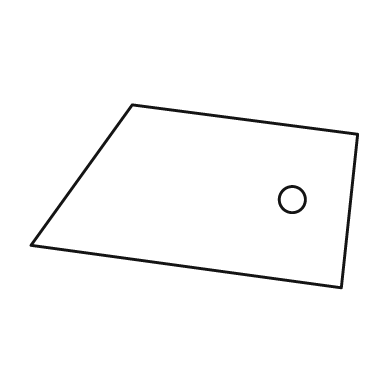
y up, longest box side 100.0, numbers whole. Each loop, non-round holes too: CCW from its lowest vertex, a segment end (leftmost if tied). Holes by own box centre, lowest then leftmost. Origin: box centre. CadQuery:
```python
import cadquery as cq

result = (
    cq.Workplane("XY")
    .moveTo(45.0, -28.0)
    .lineTo(50.0, 19.0)
    .lineTo(-19.0, 28.0)
    .lineTo(-50.0, -15.0)
    .close()
    .moveTo(30.0, -1.0)
    .circle(4.0)
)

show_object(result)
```